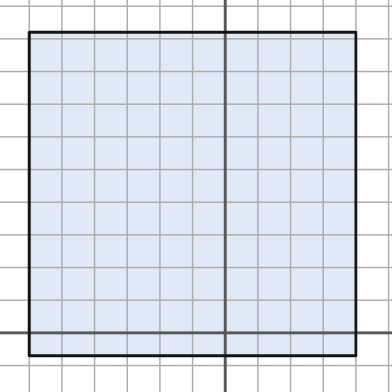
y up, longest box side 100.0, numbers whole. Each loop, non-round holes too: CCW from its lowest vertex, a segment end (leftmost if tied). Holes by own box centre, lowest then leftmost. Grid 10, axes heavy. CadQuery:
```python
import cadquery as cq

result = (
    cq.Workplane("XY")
    .moveTo(-60.0, -7.0)
    .lineTo(40.0, -7.0)
    .lineTo(40.0, 92.0)
    .lineTo(-60.0, 92.0)
    .close()
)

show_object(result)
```